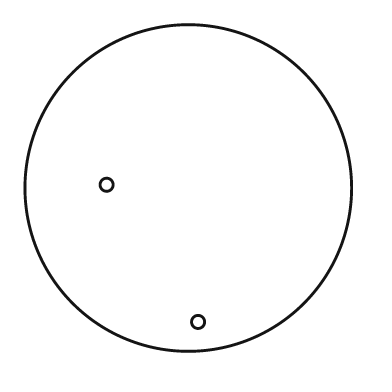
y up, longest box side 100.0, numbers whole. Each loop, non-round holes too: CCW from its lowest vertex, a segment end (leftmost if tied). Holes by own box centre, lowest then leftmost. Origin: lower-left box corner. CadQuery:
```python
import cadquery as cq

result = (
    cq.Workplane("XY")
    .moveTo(50.0, 50.0)
    .circle(50.0)
    .moveTo(53.0, 9.0)
    .circle(2.0)
    .moveTo(25.0, 51.0)
    .circle(2.0)
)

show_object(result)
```